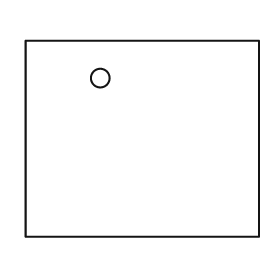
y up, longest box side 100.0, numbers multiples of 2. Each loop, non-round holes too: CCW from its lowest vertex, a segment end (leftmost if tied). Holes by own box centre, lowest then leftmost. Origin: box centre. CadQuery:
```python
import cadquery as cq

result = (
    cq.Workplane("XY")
    .moveTo(-50.0, -42.0)
    .lineTo(50.0, -42.0)
    .lineTo(50.0, 42.0)
    .lineTo(-50.0, 42.0)
    .close()
    .moveTo(-18.0, 26.0)
    .circle(4.0)
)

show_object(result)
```